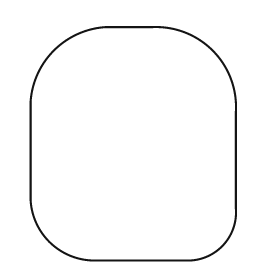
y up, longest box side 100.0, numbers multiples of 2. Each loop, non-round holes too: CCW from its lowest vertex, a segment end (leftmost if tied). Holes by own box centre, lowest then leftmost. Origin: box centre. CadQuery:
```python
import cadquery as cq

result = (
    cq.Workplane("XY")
    .moveTo(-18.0, -50.0)
    .lineTo(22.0, -50.0)
    .threePointArc((38.0, -44.0), (44.0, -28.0))
    .lineTo(44.0, 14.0)
    .threePointArc((34.0, 40.0), (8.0, 50.0))
    .lineTo(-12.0, 50.0)
    .threePointArc((-34.0, 40.0), (-44.0, 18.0))
    .lineTo(-44.0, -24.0)
    .threePointArc((-36.0, -42.0), (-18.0, -50.0))
    .close()
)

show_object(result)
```